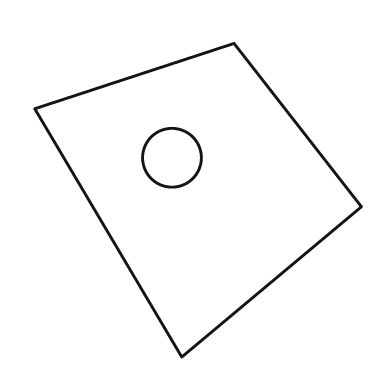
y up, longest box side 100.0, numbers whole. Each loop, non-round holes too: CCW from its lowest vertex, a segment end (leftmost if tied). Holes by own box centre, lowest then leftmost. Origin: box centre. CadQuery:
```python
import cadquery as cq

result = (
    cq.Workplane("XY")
    .moveTo(-5.0, -48.0)
    .lineTo(50.0, -2.0)
    .lineTo(11.0, 48.0)
    .lineTo(-50.0, 28.0)
    .close()
    .moveTo(-8.0, 13.0)
    .circle(9.0)
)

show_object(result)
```